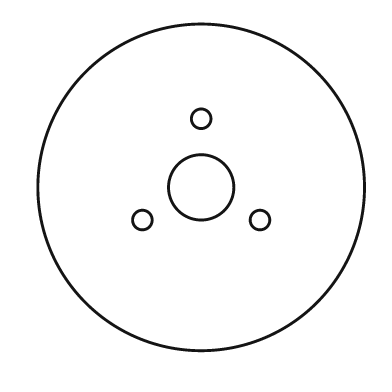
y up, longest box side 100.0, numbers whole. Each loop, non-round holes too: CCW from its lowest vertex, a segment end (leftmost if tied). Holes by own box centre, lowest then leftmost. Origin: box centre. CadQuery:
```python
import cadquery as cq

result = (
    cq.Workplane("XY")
    .moveTo(0.0, 0.0)
    .circle(50.0)
    .moveTo(-18.0, -10.0)
    .circle(3.0)
    .moveTo(18.0, -10.0)
    .circle(3.0)
    .moveTo(0.0, 0.0)
    .circle(10.0)
    .moveTo(0.0, 21.0)
    .circle(3.0)
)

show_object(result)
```